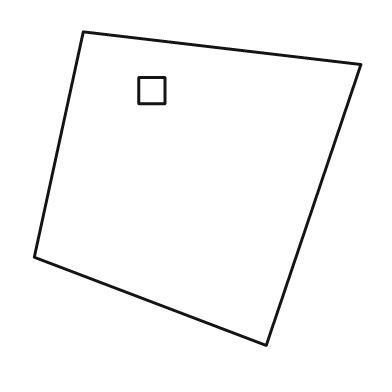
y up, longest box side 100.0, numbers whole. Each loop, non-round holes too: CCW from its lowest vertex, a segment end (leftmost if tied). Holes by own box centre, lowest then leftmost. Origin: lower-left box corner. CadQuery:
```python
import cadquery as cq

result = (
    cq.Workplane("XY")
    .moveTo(71.0, 0.0)
    .lineTo(100.0, 86.0)
    .lineTo(15.0, 96.0)
    .lineTo(0.0, 27.0)
    .close()
    .moveTo(32.0, 74.0)
    .lineTo(40.0, 74.0)
    .lineTo(40.0, 82.0)
    .lineTo(32.0, 82.0)
    .close()
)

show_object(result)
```